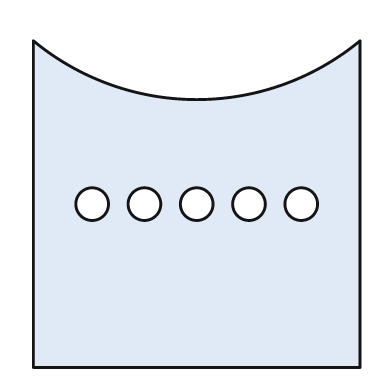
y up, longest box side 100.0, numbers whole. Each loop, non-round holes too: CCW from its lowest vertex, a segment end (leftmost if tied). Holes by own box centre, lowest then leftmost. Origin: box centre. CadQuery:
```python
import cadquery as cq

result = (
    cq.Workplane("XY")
    .moveTo(-50.0, -50.0)
    .lineTo(50.0, -50.0)
    .lineTo(50.0, 50.0)
    .threePointArc((0.0, 32.0), (-50.0, 50.0))
    .close()
    .moveTo(-32.0, 0.0)
    .circle(5.0)
    .moveTo(-16.0, 0.0)
    .circle(5.0)
    .moveTo(0.0, 0.0)
    .circle(5.0)
    .moveTo(16.0, 0.0)
    .circle(5.0)
    .moveTo(32.0, 0.0)
    .circle(5.0)
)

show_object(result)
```